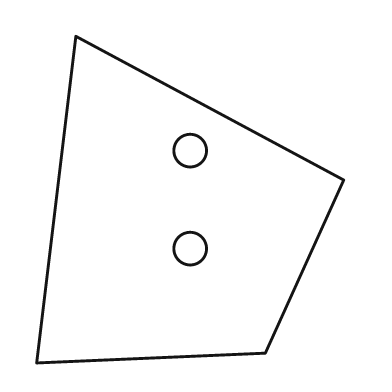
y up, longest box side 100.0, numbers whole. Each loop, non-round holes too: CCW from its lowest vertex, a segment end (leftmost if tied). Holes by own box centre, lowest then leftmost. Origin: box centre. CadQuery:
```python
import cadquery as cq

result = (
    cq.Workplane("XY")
    .moveTo(-47.0, -50.0)
    .lineTo(23.0, -47.0)
    .lineTo(47.0, 6.0)
    .lineTo(-35.0, 50.0)
    .close()
    .moveTo(0.0, -15.0)
    .circle(5.0)
    .moveTo(0.0, 15.0)
    .circle(5.0)
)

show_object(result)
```